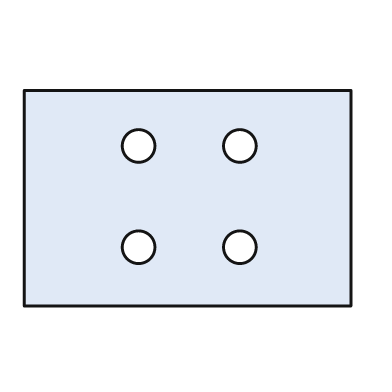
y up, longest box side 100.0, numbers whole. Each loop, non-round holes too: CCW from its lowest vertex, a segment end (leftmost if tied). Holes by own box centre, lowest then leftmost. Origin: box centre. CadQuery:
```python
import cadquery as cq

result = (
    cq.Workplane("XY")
    .moveTo(-50.0, -33.0)
    .lineTo(50.0, -33.0)
    .lineTo(50.0, 33.0)
    .lineTo(-50.0, 33.0)
    .close()
    .moveTo(-15.0, -15.0)
    .circle(5.0)
    .moveTo(16.0, -15.0)
    .circle(5.0)
    .moveTo(-15.0, 16.0)
    .circle(5.0)
    .moveTo(16.0, 16.0)
    .circle(5.0)
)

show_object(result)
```